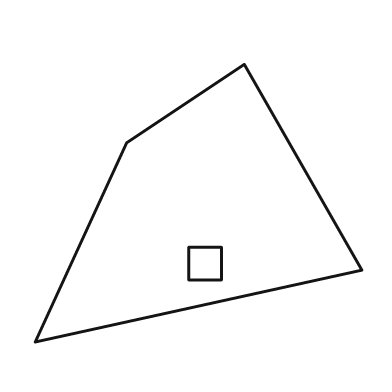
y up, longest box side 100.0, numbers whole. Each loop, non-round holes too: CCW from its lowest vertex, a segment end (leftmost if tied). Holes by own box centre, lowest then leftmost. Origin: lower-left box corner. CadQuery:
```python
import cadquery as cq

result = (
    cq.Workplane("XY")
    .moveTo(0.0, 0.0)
    .lineTo(100.0, 22.0)
    .lineTo(64.0, 85.0)
    .lineTo(28.0, 61.0)
    .close()
    .moveTo(47.0, 19.0)
    .lineTo(57.0, 19.0)
    .lineTo(57.0, 29.0)
    .lineTo(47.0, 29.0)
    .close()
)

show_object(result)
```